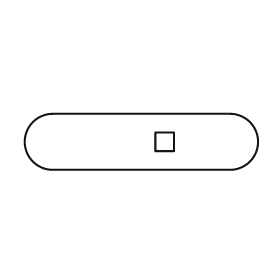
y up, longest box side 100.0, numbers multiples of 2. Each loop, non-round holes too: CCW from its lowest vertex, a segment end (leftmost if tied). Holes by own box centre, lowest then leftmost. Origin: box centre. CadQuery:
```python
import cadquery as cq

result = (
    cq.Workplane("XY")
    .moveTo(-38.0, -12.0)
    .lineTo(38.0, -12.0)
    .threePointArc((50.0, 0.0), (38.0, 12.0))
    .lineTo(-38.0, 12.0)
    .threePointArc((-50.0, 0.0), (-38.0, -12.0))
    .close()
    .moveTo(6.0, -4.0)
    .lineTo(14.0, -4.0)
    .lineTo(14.0, 4.0)
    .lineTo(6.0, 4.0)
    .close()
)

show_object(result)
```